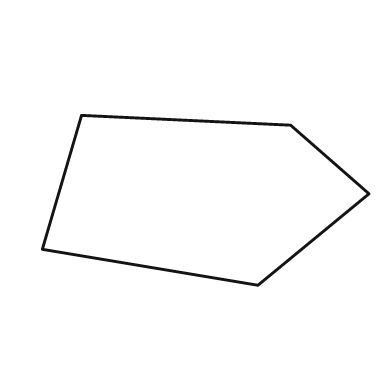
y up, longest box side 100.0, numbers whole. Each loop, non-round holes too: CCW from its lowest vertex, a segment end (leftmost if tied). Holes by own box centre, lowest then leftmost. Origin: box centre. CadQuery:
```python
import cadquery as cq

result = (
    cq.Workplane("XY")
    .moveTo(16.0, -26.0)
    .lineTo(50.0, 2.0)
    .lineTo(26.0, 23.0)
    .lineTo(-38.0, 26.0)
    .lineTo(-50.0, -15.0)
    .close()
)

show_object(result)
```